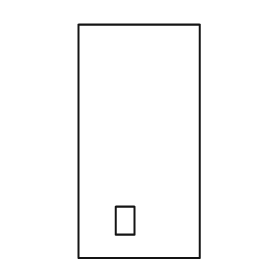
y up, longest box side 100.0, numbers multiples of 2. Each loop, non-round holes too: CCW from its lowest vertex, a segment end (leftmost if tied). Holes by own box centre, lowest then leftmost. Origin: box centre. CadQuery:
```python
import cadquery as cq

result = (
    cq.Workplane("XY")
    .moveTo(-26.0, -50.0)
    .lineTo(26.0, -50.0)
    .lineTo(26.0, 50.0)
    .lineTo(-26.0, 50.0)
    .close()
    .moveTo(-10.0, -40.0)
    .lineTo(-2.0, -40.0)
    .lineTo(-2.0, -28.0)
    .lineTo(-10.0, -28.0)
    .close()
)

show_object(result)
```